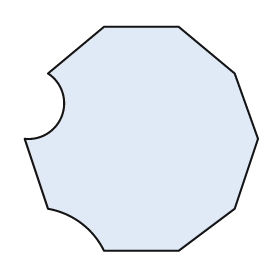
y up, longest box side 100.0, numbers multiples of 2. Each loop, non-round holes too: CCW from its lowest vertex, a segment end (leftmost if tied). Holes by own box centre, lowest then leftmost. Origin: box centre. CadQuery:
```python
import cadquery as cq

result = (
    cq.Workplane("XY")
    .moveTo(-16.0, -48.0)
    .lineTo(16.0, -48.0)
    .lineTo(40.0, -30.0)
    .lineTo(50.0, 0.0)
    .lineTo(40.0, 28.0)
    .lineTo(16.0, 48.0)
    .lineTo(-16.0, 48.0)
    .lineTo(-40.0, 28.0)
    .threePointArc((-34.0, 10.0), (-50.0, 0.0))
    .lineTo(-40.0, -30.0)
    .threePointArc((-26.0, -36.0), (-16.0, -48.0))
    .close()
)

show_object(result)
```